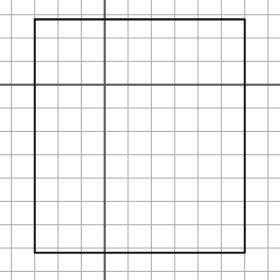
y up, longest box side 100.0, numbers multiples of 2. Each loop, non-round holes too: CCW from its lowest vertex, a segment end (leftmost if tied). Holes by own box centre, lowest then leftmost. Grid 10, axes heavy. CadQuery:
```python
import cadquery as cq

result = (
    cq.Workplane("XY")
    .moveTo(-30.0, -72.0)
    .lineTo(60.0, -72.0)
    .lineTo(60.0, 28.0)
    .lineTo(-30.0, 28.0)
    .close()
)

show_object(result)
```